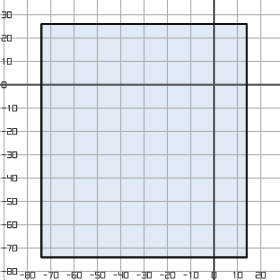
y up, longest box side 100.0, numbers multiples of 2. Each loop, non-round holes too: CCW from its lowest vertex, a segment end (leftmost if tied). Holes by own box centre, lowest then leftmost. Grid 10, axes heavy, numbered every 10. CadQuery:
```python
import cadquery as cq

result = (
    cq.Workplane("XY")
    .moveTo(-74.0, -74.0)
    .lineTo(14.0, -74.0)
    .lineTo(14.0, 26.0)
    .lineTo(-74.0, 26.0)
    .close()
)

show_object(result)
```